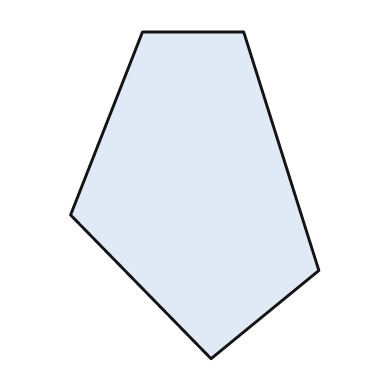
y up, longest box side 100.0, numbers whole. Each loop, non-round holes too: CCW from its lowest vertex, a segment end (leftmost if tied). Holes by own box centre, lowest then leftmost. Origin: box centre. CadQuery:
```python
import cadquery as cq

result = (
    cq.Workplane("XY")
    .moveTo(5.0, -50.0)
    .lineTo(38.0, -23.0)
    .lineTo(15.0, 50.0)
    .lineTo(-16.0, 50.0)
    .lineTo(-38.0, -6.0)
    .close()
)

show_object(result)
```